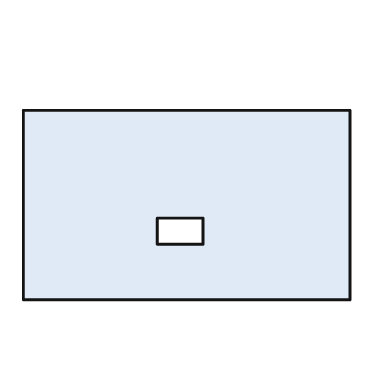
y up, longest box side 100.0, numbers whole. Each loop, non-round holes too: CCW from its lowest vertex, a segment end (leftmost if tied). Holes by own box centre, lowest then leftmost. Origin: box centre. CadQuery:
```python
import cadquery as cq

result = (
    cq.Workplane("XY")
    .moveTo(-50.0, -29.0)
    .lineTo(50.0, -29.0)
    .lineTo(50.0, 29.0)
    .lineTo(-50.0, 29.0)
    .close()
    .moveTo(-9.0, -12.0)
    .lineTo(5.0, -12.0)
    .lineTo(5.0, -4.0)
    .lineTo(-9.0, -4.0)
    .close()
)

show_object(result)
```